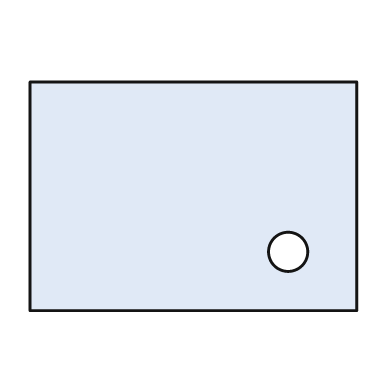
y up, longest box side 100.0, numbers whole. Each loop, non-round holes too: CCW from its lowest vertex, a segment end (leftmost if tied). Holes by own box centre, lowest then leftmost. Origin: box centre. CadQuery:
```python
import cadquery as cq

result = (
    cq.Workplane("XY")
    .moveTo(-50.0, -35.0)
    .lineTo(50.0, -35.0)
    .lineTo(50.0, 35.0)
    .lineTo(-50.0, 35.0)
    .close()
    .moveTo(29.0, -17.0)
    .circle(6.0)
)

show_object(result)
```